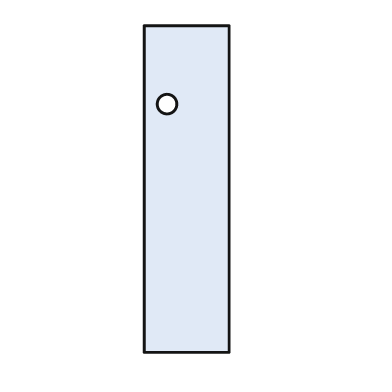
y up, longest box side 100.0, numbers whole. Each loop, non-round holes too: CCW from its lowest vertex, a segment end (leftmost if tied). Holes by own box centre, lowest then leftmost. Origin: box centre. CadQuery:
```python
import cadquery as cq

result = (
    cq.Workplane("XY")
    .moveTo(-13.0, -50.0)
    .lineTo(13.0, -50.0)
    .lineTo(13.0, 50.0)
    .lineTo(-13.0, 50.0)
    .close()
    .moveTo(-6.0, 26.0)
    .circle(3.0)
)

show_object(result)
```